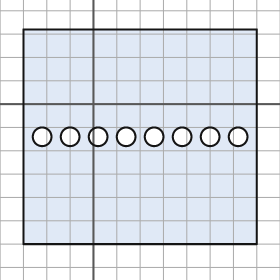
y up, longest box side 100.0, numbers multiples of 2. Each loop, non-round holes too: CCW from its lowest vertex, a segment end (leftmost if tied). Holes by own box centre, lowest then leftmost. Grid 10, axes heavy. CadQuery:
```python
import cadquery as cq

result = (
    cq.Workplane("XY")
    .moveTo(-30.0, -60.0)
    .lineTo(70.0, -60.0)
    .lineTo(70.0, 32.0)
    .lineTo(-30.0, 32.0)
    .close()
    .moveTo(-22.0, -14.0)
    .circle(4.0)
    .moveTo(-10.0, -14.0)
    .circle(4.0)
    .moveTo(2.0, -14.0)
    .circle(4.0)
    .moveTo(14.0, -14.0)
    .circle(4.0)
    .moveTo(26.0, -14.0)
    .circle(4.0)
    .moveTo(38.0, -14.0)
    .circle(4.0)
    .moveTo(50.0, -14.0)
    .circle(4.0)
    .moveTo(62.0, -14.0)
    .circle(4.0)
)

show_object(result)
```